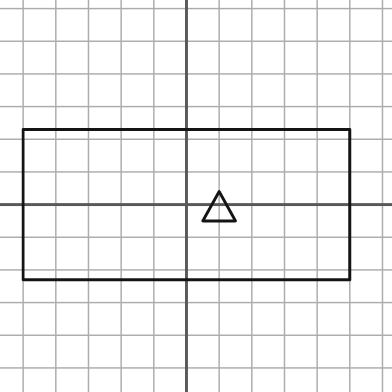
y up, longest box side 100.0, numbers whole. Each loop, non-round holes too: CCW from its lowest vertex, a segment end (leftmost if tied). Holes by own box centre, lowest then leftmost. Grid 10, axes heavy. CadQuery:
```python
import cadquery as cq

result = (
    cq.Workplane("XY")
    .moveTo(-50.0, -23.0)
    .lineTo(50.0, -23.0)
    .lineTo(50.0, 23.0)
    .lineTo(-50.0, 23.0)
    .close()
    .moveTo(5.0, -5.0)
    .lineTo(15.0, -5.0)
    .lineTo(10.0, 4.0)
    .close()
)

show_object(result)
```